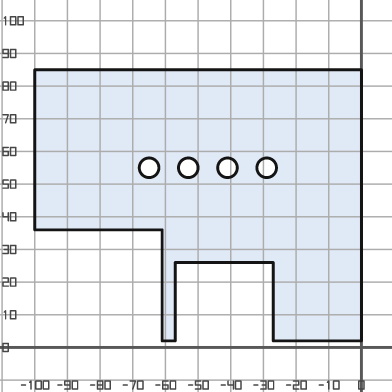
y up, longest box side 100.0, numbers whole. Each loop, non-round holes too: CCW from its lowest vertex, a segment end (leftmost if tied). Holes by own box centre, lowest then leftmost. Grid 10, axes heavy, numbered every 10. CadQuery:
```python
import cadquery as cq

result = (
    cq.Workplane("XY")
    .moveTo(-61.0, 2.0)
    .lineTo(-57.0, 2.0)
    .lineTo(-57.0, 26.0)
    .lineTo(-27.0, 26.0)
    .lineTo(-27.0, 2.0)
    .lineTo(0.0, 2.0)
    .lineTo(0.0, 85.0)
    .lineTo(-100.0, 85.0)
    .lineTo(-100.0, 36.0)
    .lineTo(-61.0, 36.0)
    .close()
    .moveTo(-65.0, 55.0)
    .circle(3.0)
    .moveTo(-53.0, 55.0)
    .circle(3.0)
    .moveTo(-41.0, 55.0)
    .circle(3.0)
    .moveTo(-29.0, 55.0)
    .circle(3.0)
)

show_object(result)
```